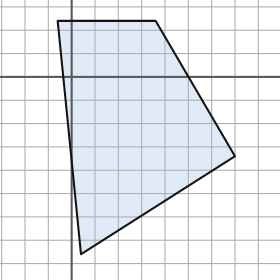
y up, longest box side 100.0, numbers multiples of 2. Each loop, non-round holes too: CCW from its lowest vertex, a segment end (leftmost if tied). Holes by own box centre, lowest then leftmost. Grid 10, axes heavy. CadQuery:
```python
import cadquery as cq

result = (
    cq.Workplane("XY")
    .moveTo(4.0, -76.0)
    .lineTo(70.0, -34.0)
    .lineTo(36.0, 24.0)
    .lineTo(-6.0, 24.0)
    .close()
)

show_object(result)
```